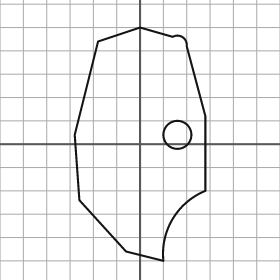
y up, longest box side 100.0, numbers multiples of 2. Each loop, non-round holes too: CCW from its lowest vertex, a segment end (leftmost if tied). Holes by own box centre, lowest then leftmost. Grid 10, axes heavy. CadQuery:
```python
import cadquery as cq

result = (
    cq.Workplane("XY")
    .moveTo(10.0, -50.0)
    .threePointArc((14.0, -32.0), (28.0, -20.0))
    .lineTo(28.0, 12.0)
    .lineTo(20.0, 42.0)
    .threePointArc((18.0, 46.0), (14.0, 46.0))
    .lineTo(0.0, 50.0)
    .lineTo(-18.0, 44.0)
    .lineTo(-28.0, 4.0)
    .lineTo(-26.0, -24.0)
    .lineTo(-6.0, -46.0)
    .close()
    .moveTo(16.0, 4.0)
    .circle(6.0)
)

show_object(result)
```